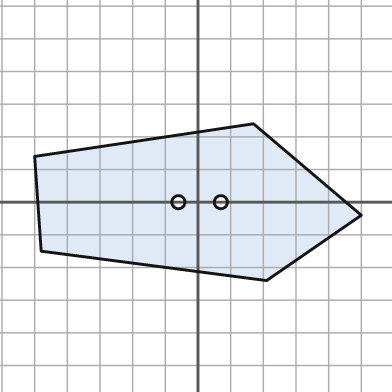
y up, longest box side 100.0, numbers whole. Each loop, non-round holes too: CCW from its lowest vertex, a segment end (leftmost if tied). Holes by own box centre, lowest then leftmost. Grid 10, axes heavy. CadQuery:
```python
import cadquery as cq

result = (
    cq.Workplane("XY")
    .moveTo(21.0, -24.0)
    .lineTo(50.0, -4.0)
    .lineTo(17.0, 24.0)
    .lineTo(-50.0, 14.0)
    .lineTo(-48.0, -15.0)
    .close()
    .moveTo(-6.0, 0.0)
    .circle(2.0)
    .moveTo(7.0, 0.0)
    .circle(2.0)
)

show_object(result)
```